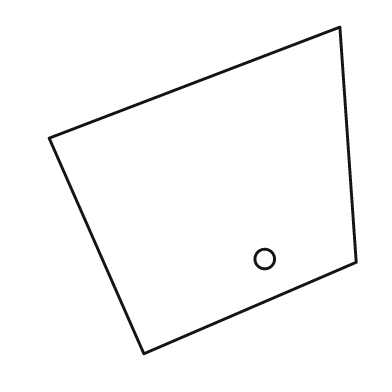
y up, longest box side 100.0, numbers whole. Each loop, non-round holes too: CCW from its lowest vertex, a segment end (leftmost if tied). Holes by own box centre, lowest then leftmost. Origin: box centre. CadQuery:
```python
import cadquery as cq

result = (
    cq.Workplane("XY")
    .moveTo(-18.0, -50.0)
    .lineTo(47.0, -22.0)
    .lineTo(42.0, 50.0)
    .lineTo(-47.0, 16.0)
    .close()
    .moveTo(19.0, -21.0)
    .circle(3.0)
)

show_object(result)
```